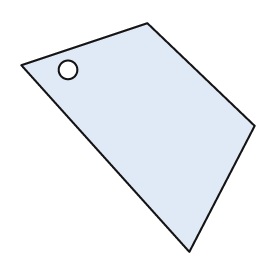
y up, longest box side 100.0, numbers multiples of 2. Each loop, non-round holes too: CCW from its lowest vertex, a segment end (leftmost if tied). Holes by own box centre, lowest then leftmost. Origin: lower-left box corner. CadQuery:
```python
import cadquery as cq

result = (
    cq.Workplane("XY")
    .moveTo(72.0, 0.0)
    .lineTo(100.0, 54.0)
    .lineTo(54.0, 98.0)
    .lineTo(0.0, 80.0)
    .close()
    .moveTo(20.0, 78.0)
    .circle(4.0)
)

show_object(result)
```